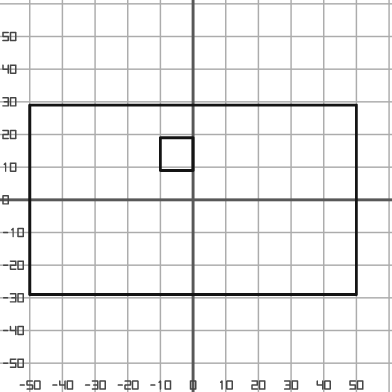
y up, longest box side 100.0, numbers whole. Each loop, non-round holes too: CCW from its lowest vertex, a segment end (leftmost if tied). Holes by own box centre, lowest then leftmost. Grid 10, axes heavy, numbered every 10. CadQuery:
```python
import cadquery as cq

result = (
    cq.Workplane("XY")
    .moveTo(-50.0, -29.0)
    .lineTo(50.0, -29.0)
    .lineTo(50.0, 29.0)
    .lineTo(-50.0, 29.0)
    .close()
    .moveTo(-10.0, 9.0)
    .lineTo(0.0, 9.0)
    .lineTo(0.0, 19.0)
    .lineTo(-10.0, 19.0)
    .close()
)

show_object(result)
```